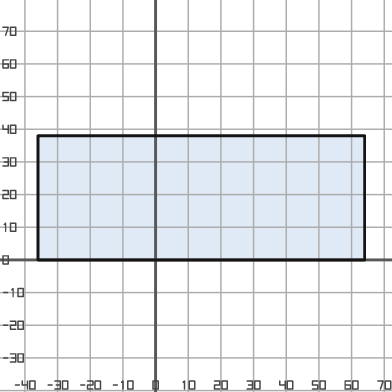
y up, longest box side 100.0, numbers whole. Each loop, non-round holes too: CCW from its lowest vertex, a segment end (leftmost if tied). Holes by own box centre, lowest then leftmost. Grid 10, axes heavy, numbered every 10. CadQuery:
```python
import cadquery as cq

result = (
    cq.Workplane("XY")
    .moveTo(-36.0, 0.0)
    .lineTo(64.0, 0.0)
    .lineTo(64.0, 38.0)
    .lineTo(-36.0, 38.0)
    .close()
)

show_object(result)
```